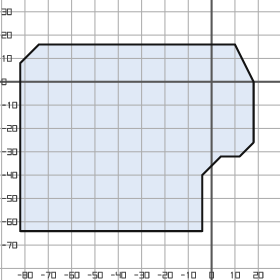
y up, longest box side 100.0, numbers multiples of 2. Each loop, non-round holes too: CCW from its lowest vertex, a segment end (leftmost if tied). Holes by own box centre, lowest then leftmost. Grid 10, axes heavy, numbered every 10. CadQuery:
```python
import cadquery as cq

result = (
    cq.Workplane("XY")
    .moveTo(-82.0, -64.0)
    .lineTo(-4.0, -64.0)
    .lineTo(-4.0, -40.0)
    .lineTo(4.0, -32.0)
    .lineTo(12.0, -32.0)
    .lineTo(18.0, -26.0)
    .lineTo(18.0, 0.0)
    .lineTo(10.0, 16.0)
    .lineTo(-74.0, 16.0)
    .lineTo(-82.0, 8.0)
    .close()
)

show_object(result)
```